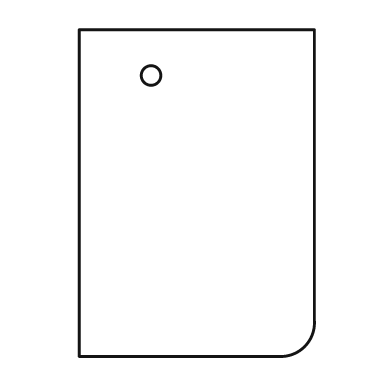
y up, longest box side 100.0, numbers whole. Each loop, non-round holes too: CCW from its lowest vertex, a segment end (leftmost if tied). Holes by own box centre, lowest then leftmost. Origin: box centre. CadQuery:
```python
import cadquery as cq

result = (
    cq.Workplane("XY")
    .moveTo(-36.0, -50.0)
    .lineTo(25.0, -50.0)
    .threePointArc((33.0, -47.0), (36.0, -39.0))
    .lineTo(36.0, 50.0)
    .lineTo(-36.0, 50.0)
    .close()
    .moveTo(-14.0, 36.0)
    .circle(3.0)
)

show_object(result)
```